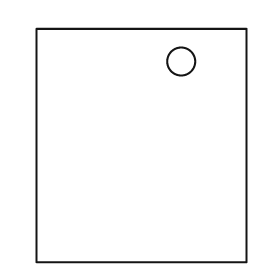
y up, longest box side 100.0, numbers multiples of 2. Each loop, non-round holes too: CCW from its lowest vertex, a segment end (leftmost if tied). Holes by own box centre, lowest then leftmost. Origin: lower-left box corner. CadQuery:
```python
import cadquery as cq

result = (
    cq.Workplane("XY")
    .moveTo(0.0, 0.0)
    .lineTo(90.0, 0.0)
    .lineTo(90.0, 100.0)
    .lineTo(0.0, 100.0)
    .close()
    .moveTo(62.0, 86.0)
    .circle(6.0)
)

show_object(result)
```